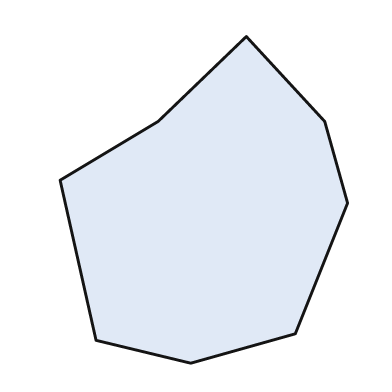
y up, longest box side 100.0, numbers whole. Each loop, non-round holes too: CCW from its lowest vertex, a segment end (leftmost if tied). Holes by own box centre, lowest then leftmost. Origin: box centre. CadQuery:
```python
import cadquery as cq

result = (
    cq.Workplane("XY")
    .moveTo(-4.0, -50.0)
    .lineTo(28.0, -41.0)
    .lineTo(44.0, -1.0)
    .lineTo(37.0, 24.0)
    .lineTo(13.0, 50.0)
    .lineTo(-14.0, 24.0)
    .lineTo(-44.0, 6.0)
    .lineTo(-33.0, -43.0)
    .close()
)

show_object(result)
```